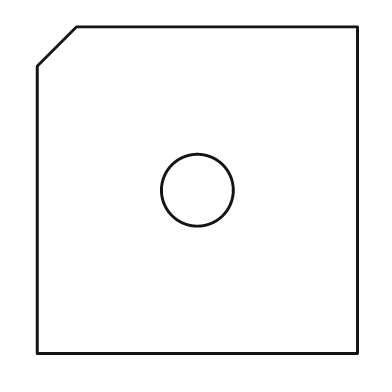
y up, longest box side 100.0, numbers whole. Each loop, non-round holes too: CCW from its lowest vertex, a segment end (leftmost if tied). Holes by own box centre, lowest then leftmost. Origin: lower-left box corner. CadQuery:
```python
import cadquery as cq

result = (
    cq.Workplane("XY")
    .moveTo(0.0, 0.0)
    .lineTo(98.0, 0.0)
    .lineTo(98.0, 100.0)
    .lineTo(12.0, 100.0)
    .lineTo(0.0, 88.0)
    .close()
    .moveTo(49.0, 50.0)
    .circle(11.0)
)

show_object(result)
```